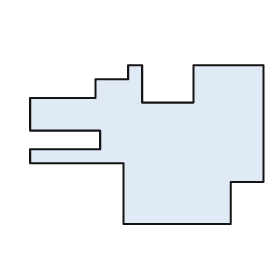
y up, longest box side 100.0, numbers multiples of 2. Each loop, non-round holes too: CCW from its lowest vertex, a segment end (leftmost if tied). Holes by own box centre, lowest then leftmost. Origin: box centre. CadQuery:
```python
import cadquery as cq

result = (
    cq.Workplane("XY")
    .moveTo(-10.0, -34.0)
    .lineTo(36.0, -34.0)
    .lineTo(36.0, -16.0)
    .lineTo(50.0, -16.0)
    .lineTo(50.0, 34.0)
    .lineTo(20.0, 34.0)
    .lineTo(20.0, 18.0)
    .lineTo(-2.0, 18.0)
    .lineTo(-2.0, 34.0)
    .lineTo(-8.0, 34.0)
    .lineTo(-8.0, 28.0)
    .lineTo(-22.0, 28.0)
    .lineTo(-22.0, 20.0)
    .lineTo(-50.0, 20.0)
    .lineTo(-50.0, 6.0)
    .lineTo(-20.0, 6.0)
    .lineTo(-20.0, -2.0)
    .lineTo(-50.0, -2.0)
    .lineTo(-50.0, -8.0)
    .lineTo(-10.0, -8.0)
    .close()
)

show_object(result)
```